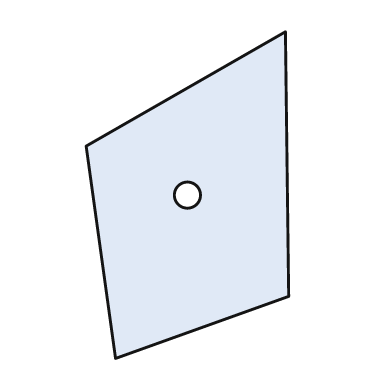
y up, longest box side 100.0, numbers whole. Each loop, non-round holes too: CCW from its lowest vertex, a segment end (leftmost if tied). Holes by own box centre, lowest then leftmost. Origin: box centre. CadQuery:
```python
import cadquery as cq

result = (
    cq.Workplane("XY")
    .moveTo(-22.0, -50.0)
    .lineTo(31.0, -31.0)
    .lineTo(30.0, 50.0)
    .lineTo(-31.0, 15.0)
    .close()
    .moveTo(0.0, 0.0)
    .circle(4.0)
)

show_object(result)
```